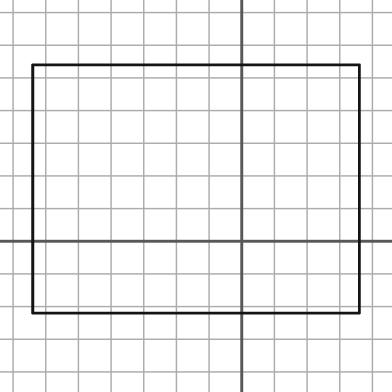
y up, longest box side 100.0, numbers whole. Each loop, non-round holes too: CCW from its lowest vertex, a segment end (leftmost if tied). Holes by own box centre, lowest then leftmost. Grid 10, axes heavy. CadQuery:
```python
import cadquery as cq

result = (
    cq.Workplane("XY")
    .moveTo(-64.0, -22.0)
    .lineTo(36.0, -22.0)
    .lineTo(36.0, 54.0)
    .lineTo(-64.0, 54.0)
    .close()
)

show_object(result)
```